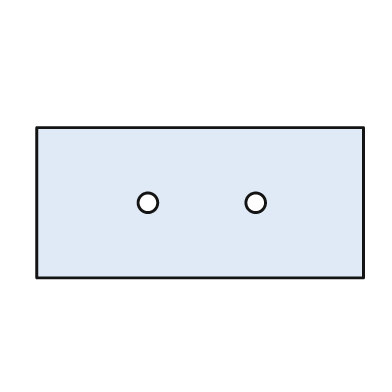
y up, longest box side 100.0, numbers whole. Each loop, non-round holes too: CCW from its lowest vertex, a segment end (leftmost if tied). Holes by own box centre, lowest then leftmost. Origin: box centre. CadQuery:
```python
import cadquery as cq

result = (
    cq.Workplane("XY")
    .moveTo(-50.0, -23.0)
    .lineTo(50.0, -23.0)
    .lineTo(50.0, 23.0)
    .lineTo(-50.0, 23.0)
    .close()
    .moveTo(-16.0, 0.0)
    .circle(3.0)
    .moveTo(17.0, 0.0)
    .circle(3.0)
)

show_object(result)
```